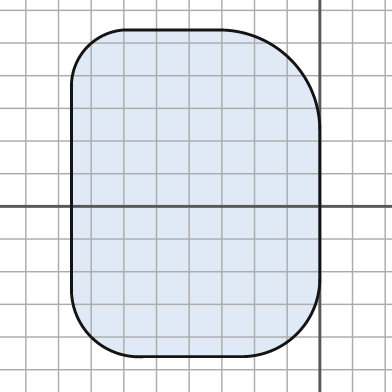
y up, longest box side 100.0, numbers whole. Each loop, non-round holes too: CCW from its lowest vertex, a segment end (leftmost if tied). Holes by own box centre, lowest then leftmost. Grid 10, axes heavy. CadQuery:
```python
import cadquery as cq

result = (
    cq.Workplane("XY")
    .moveTo(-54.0, -46.0)
    .lineTo(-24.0, -46.0)
    .threePointArc((-7.0, -39.0), (0.0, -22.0))
    .lineTo(0.0, 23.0)
    .threePointArc((-9.0, 45.0), (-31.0, 54.0))
    .lineTo(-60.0, 54.0)
    .threePointArc((-71.0, 49.0), (-76.0, 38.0))
    .lineTo(-76.0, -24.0)
    .threePointArc((-70.0, -40.0), (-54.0, -46.0))
    .close()
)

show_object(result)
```